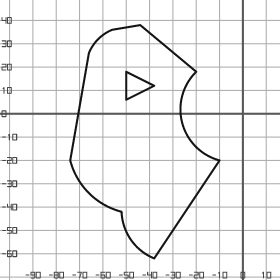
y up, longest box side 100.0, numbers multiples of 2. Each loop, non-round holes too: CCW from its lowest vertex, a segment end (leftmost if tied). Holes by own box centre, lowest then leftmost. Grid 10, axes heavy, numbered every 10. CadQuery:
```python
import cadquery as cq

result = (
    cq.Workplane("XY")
    .moveTo(-38.0, -62.0)
    .lineTo(-10.0, -20.0)
    .threePointArc((-26.0, -4.0), (-20.0, 18.0))
    .lineTo(-44.0, 38.0)
    .lineTo(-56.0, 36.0)
    .threePointArc((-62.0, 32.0), (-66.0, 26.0))
    .lineTo(-74.0, -20.0)
    .threePointArc((-66.0, -34.0), (-52.0, -42.0))
    .threePointArc((-48.0, -54.0), (-38.0, -62.0))
    .close()
    .moveTo(-50.0, 6.0)
    .lineTo(-38.0, 12.0)
    .lineTo(-50.0, 18.0)
    .close()
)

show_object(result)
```